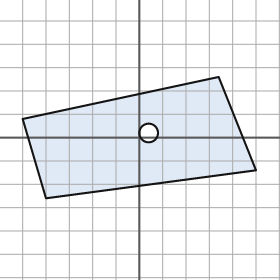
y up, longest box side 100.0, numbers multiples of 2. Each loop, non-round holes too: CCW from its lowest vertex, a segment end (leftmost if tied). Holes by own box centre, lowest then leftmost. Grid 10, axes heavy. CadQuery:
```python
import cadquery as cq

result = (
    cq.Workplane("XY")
    .moveTo(-40.0, -26.0)
    .lineTo(50.0, -14.0)
    .lineTo(34.0, 26.0)
    .lineTo(-50.0, 8.0)
    .close()
    .moveTo(4.0, 2.0)
    .circle(4.0)
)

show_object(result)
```